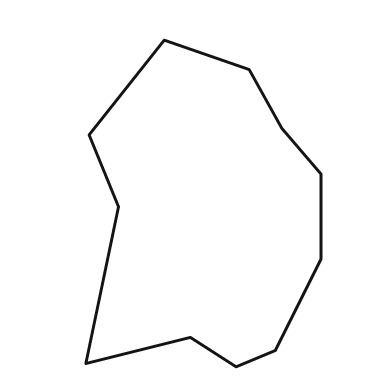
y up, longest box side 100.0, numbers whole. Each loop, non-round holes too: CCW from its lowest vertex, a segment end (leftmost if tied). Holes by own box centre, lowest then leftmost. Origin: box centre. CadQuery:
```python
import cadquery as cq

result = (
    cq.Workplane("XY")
    .moveTo(10.0, -50.0)
    .lineTo(22.0, -45.0)
    .lineTo(36.0, -17.0)
    .lineTo(36.0, 9.0)
    .lineTo(24.0, 23.0)
    .lineTo(14.0, 41.0)
    .lineTo(-12.0, 50.0)
    .lineTo(-35.0, 21.0)
    .lineTo(-26.0, -1.0)
    .lineTo(-36.0, -49.0)
    .lineTo(-4.0, -41.0)
    .close()
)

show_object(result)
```